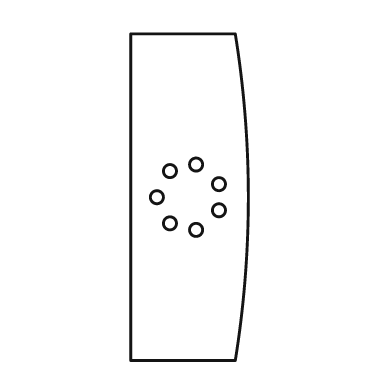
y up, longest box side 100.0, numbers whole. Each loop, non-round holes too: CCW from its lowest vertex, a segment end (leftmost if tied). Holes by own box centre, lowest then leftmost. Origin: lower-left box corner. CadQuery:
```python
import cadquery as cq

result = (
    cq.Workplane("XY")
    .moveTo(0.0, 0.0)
    .lineTo(32.0, 0.0)
    .threePointArc((36.0, 50.0), (32.0, 100.0))
    .lineTo(0.0, 100.0)
    .close()
    .moveTo(20.0, 40.0)
    .circle(2.0)
    .moveTo(12.0, 42.0)
    .circle(2.0)
    .moveTo(27.0, 46.0)
    .circle(2.0)
    .moveTo(8.0, 50.0)
    .circle(2.0)
    .moveTo(27.0, 54.0)
    .circle(2.0)
    .moveTo(12.0, 58.0)
    .circle(2.0)
    .moveTo(20.0, 60.0)
    .circle(2.0)
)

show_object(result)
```